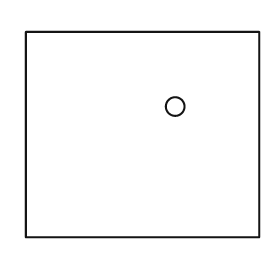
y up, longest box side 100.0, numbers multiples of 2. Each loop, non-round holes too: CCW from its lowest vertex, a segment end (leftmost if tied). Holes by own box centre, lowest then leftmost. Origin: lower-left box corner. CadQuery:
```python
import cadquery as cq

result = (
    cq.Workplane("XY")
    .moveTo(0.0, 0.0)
    .lineTo(100.0, 0.0)
    .lineTo(100.0, 88.0)
    .lineTo(0.0, 88.0)
    .close()
    .moveTo(64.0, 56.0)
    .circle(4.0)
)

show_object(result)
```